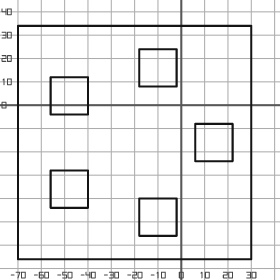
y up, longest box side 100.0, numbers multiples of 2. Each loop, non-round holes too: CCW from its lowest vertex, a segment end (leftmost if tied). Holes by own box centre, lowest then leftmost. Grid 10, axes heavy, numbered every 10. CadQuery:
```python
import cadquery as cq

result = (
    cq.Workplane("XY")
    .moveTo(-70.0, -66.0)
    .lineTo(30.0, -66.0)
    .lineTo(30.0, 34.0)
    .lineTo(-70.0, 34.0)
    .close()
    .moveTo(-18.0, -56.0)
    .lineTo(-2.0, -56.0)
    .lineTo(-2.0, -40.0)
    .lineTo(-18.0, -40.0)
    .close()
    .moveTo(-56.0, -44.0)
    .lineTo(-40.0, -44.0)
    .lineTo(-40.0, -28.0)
    .lineTo(-56.0, -28.0)
    .close()
    .moveTo(6.0, -24.0)
    .lineTo(22.0, -24.0)
    .lineTo(22.0, -8.0)
    .lineTo(6.0, -8.0)
    .close()
    .moveTo(-56.0, -4.0)
    .lineTo(-40.0, -4.0)
    .lineTo(-40.0, 12.0)
    .lineTo(-56.0, 12.0)
    .close()
    .moveTo(-18.0, 8.0)
    .lineTo(-2.0, 8.0)
    .lineTo(-2.0, 24.0)
    .lineTo(-18.0, 24.0)
    .close()
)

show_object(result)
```